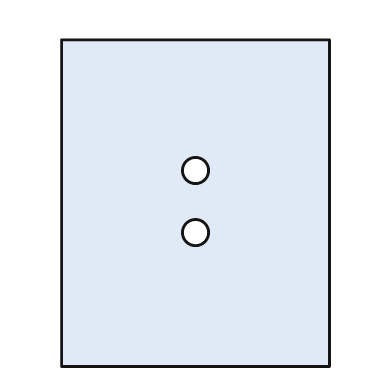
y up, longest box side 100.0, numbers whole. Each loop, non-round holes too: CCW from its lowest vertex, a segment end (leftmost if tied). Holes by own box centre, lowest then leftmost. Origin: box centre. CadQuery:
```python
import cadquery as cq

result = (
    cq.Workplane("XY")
    .moveTo(-41.0, -50.0)
    .lineTo(41.0, -50.0)
    .lineTo(41.0, 50.0)
    .lineTo(-41.0, 50.0)
    .close()
    .moveTo(0.0, -9.0)
    .circle(4.0)
    .moveTo(0.0, 10.0)
    .circle(4.0)
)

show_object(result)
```